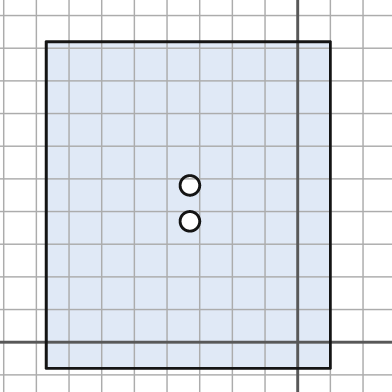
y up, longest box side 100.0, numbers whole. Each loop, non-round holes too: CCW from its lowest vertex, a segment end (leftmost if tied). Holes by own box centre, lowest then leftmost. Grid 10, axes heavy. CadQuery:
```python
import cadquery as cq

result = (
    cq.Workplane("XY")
    .moveTo(-77.0, -8.0)
    .lineTo(10.0, -8.0)
    .lineTo(10.0, 92.0)
    .lineTo(-77.0, 92.0)
    .close()
    .moveTo(-33.0, 37.0)
    .circle(3.0)
    .moveTo(-33.0, 48.0)
    .circle(3.0)
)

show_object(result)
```